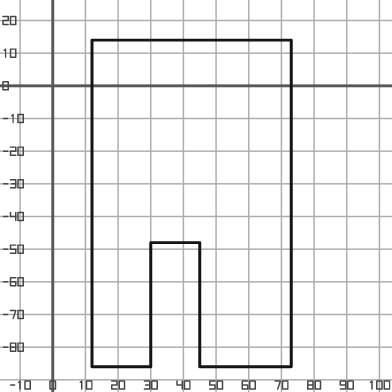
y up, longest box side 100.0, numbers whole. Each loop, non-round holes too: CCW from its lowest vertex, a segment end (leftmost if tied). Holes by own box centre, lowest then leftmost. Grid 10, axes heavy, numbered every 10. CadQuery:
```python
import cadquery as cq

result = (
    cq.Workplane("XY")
    .moveTo(12.0, -86.0)
    .lineTo(30.0, -86.0)
    .lineTo(30.0, -48.0)
    .lineTo(45.0, -48.0)
    .lineTo(45.0, -86.0)
    .lineTo(73.0, -86.0)
    .lineTo(73.0, 14.0)
    .lineTo(12.0, 14.0)
    .close()
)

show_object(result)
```